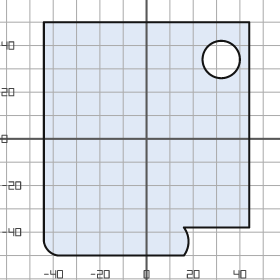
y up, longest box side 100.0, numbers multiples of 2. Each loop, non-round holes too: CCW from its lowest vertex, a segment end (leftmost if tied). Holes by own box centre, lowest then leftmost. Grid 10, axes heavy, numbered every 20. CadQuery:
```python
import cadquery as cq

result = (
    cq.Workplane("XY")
    .moveTo(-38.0, -50.0)
    .lineTo(16.0, -50.0)
    .threePointArc((18.0, -44.0), (16.0, -38.0))
    .lineTo(44.0, -38.0)
    .lineTo(44.0, 50.0)
    .lineTo(-44.0, 50.0)
    .lineTo(-44.0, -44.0)
    .threePointArc((-42.0, -48.0), (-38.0, -50.0))
    .close()
    .moveTo(32.0, 34.0)
    .circle(8.0)
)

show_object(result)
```